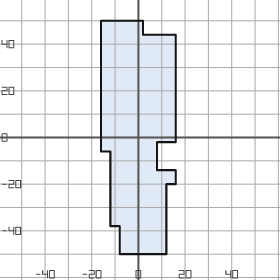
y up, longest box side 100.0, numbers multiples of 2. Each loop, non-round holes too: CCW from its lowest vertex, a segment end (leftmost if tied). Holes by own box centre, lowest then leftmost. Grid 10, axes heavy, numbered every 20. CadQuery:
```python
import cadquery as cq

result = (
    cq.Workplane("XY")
    .moveTo(-8.0, -50.0)
    .lineTo(12.0, -50.0)
    .lineTo(12.0, -20.0)
    .lineTo(16.0, -20.0)
    .lineTo(16.0, -14.0)
    .lineTo(8.0, -14.0)
    .lineTo(8.0, -2.0)
    .lineTo(16.0, -2.0)
    .lineTo(16.0, 44.0)
    .lineTo(2.0, 44.0)
    .lineTo(2.0, 50.0)
    .lineTo(-16.0, 50.0)
    .lineTo(-16.0, -6.0)
    .lineTo(-12.0, -6.0)
    .lineTo(-12.0, -38.0)
    .lineTo(-8.0, -38.0)
    .close()
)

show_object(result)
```